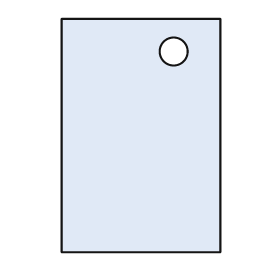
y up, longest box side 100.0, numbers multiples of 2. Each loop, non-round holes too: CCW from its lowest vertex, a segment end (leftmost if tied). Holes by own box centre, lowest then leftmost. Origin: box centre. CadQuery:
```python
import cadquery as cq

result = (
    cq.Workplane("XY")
    .moveTo(-34.0, -50.0)
    .lineTo(34.0, -50.0)
    .lineTo(34.0, 50.0)
    .lineTo(-34.0, 50.0)
    .close()
    .moveTo(14.0, 36.0)
    .circle(6.0)
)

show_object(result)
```